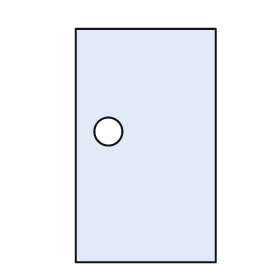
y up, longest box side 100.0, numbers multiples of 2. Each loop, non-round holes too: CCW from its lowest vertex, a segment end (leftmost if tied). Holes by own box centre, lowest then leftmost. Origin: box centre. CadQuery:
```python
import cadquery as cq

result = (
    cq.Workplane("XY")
    .moveTo(-30.0, -50.0)
    .lineTo(30.0, -50.0)
    .lineTo(30.0, 50.0)
    .lineTo(-30.0, 50.0)
    .close()
    .moveTo(-16.0, 6.0)
    .circle(6.0)
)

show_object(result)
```